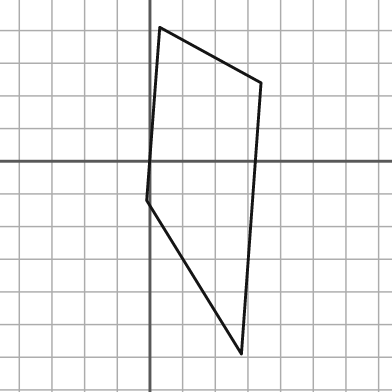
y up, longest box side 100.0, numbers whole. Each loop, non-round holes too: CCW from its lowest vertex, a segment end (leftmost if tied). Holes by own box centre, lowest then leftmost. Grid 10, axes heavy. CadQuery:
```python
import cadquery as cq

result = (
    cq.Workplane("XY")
    .moveTo(28.0, -59.0)
    .lineTo(34.0, 24.0)
    .lineTo(3.0, 41.0)
    .lineTo(-1.0, -12.0)
    .close()
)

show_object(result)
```